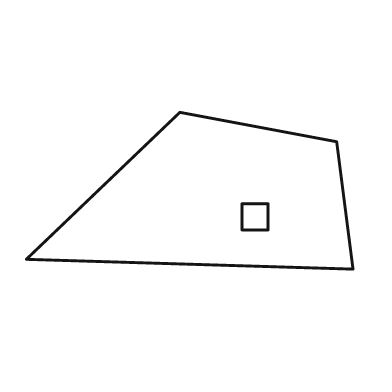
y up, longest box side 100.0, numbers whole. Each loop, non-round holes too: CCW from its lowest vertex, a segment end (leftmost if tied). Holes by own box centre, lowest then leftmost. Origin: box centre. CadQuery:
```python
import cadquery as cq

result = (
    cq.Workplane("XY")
    .moveTo(50.0, -24.0)
    .lineTo(45.0, 15.0)
    .lineTo(-3.0, 24.0)
    .lineTo(-50.0, -21.0)
    .close()
    .moveTo(16.0, -12.0)
    .lineTo(24.0, -12.0)
    .lineTo(24.0, -4.0)
    .lineTo(16.0, -4.0)
    .close()
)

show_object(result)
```